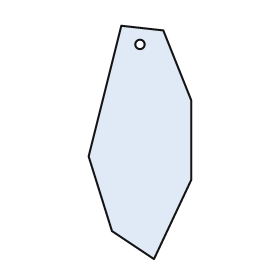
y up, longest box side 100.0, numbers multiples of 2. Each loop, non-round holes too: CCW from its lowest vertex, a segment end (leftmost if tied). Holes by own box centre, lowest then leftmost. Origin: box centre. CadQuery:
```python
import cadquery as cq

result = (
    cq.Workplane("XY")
    .moveTo(6.0, -50.0)
    .lineTo(22.0, -16.0)
    .lineTo(22.0, 18.0)
    .lineTo(10.0, 48.0)
    .lineTo(-8.0, 50.0)
    .lineTo(-22.0, -6.0)
    .lineTo(-12.0, -38.0)
    .close()
    .moveTo(0.0, 42.0)
    .circle(2.0)
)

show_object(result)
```